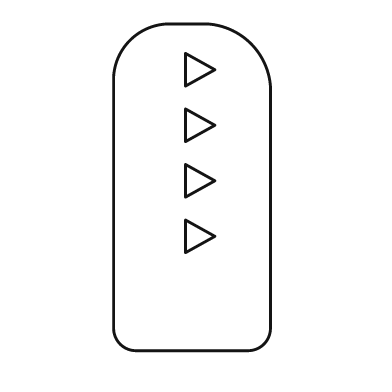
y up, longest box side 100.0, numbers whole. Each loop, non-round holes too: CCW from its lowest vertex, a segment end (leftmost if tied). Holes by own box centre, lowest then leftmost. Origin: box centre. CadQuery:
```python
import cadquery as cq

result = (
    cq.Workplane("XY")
    .moveTo(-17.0, -50.0)
    .lineTo(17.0, -50.0)
    .threePointArc((22.0, -48.0), (24.0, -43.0))
    .lineTo(24.0, 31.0)
    .threePointArc((18.0, 44.0), (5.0, 50.0))
    .lineTo(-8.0, 50.0)
    .threePointArc((-19.0, 45.0), (-24.0, 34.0))
    .lineTo(-24.0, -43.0)
    .threePointArc((-22.0, -48.0), (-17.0, -50.0))
    .close()
    .moveTo(-2.0, -20.0)
    .lineTo(7.0, -15.0)
    .lineTo(-2.0, -10.0)
    .close()
    .moveTo(-2.0, -3.0)
    .lineTo(7.0, 2.0)
    .lineTo(-2.0, 7.0)
    .close()
    .moveTo(-2.0, 14.0)
    .lineTo(7.0, 19.0)
    .lineTo(-2.0, 24.0)
    .close()
    .moveTo(-2.0, 31.0)
    .lineTo(7.0, 36.0)
    .lineTo(-2.0, 41.0)
    .close()
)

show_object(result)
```